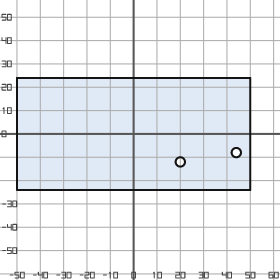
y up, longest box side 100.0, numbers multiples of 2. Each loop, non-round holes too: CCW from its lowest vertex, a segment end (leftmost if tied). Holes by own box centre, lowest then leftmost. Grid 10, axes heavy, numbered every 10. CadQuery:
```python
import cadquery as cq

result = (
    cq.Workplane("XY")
    .moveTo(-50.0, -24.0)
    .lineTo(50.0, -24.0)
    .lineTo(50.0, 24.0)
    .lineTo(-50.0, 24.0)
    .close()
    .moveTo(20.0, -12.0)
    .circle(2.0)
    .moveTo(44.0, -8.0)
    .circle(2.0)
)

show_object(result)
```